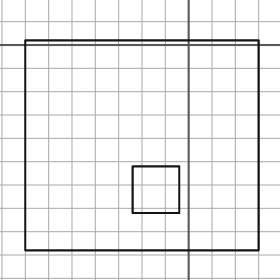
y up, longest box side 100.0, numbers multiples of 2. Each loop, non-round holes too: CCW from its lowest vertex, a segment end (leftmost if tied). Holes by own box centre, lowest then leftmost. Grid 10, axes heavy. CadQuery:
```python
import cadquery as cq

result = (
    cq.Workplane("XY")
    .moveTo(-70.0, -88.0)
    .lineTo(30.0, -88.0)
    .lineTo(30.0, 2.0)
    .lineTo(-70.0, 2.0)
    .close()
    .moveTo(-24.0, -72.0)
    .lineTo(-4.0, -72.0)
    .lineTo(-4.0, -52.0)
    .lineTo(-24.0, -52.0)
    .close()
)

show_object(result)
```